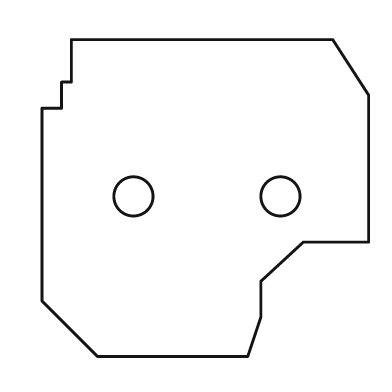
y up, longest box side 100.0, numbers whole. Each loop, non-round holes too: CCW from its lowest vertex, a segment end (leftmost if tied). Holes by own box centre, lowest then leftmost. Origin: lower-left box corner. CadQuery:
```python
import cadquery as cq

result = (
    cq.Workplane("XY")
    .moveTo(17.0, 0.0)
    .lineTo(63.0, 0.0)
    .lineTo(67.0, 12.0)
    .lineTo(67.0, 23.0)
    .lineTo(80.0, 35.0)
    .lineTo(100.0, 35.0)
    .lineTo(100.0, 80.0)
    .lineTo(89.0, 97.0)
    .lineTo(9.0, 97.0)
    .lineTo(9.0, 84.0)
    .lineTo(6.0, 84.0)
    .lineTo(6.0, 76.0)
    .lineTo(0.0, 76.0)
    .lineTo(0.0, 17.0)
    .close()
    .moveTo(28.0, 49.0)
    .circle(6.0)
    .moveTo(73.0, 49.0)
    .circle(6.0)
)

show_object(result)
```